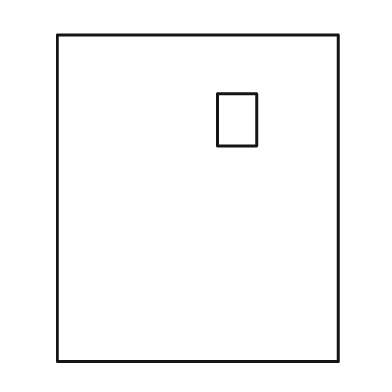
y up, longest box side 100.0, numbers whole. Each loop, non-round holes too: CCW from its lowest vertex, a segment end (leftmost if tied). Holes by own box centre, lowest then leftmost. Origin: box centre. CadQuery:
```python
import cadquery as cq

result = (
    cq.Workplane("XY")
    .moveTo(-43.0, -50.0)
    .lineTo(43.0, -50.0)
    .lineTo(43.0, 50.0)
    .lineTo(-43.0, 50.0)
    .close()
    .moveTo(6.0, 16.0)
    .lineTo(18.0, 16.0)
    .lineTo(18.0, 32.0)
    .lineTo(6.0, 32.0)
    .close()
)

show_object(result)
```